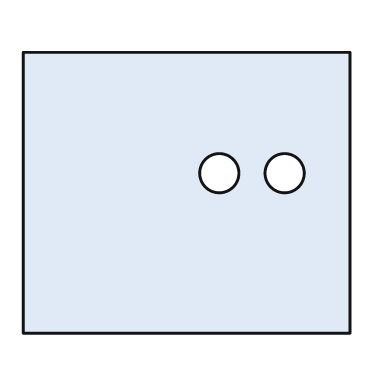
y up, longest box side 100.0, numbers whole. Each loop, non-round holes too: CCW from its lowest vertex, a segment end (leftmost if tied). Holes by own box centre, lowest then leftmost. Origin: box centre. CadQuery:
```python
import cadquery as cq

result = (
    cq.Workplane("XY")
    .moveTo(-50.0, -43.0)
    .lineTo(50.0, -43.0)
    .lineTo(50.0, 43.0)
    .lineTo(-50.0, 43.0)
    .close()
    .moveTo(10.0, 6.0)
    .circle(6.0)
    .moveTo(30.0, 6.0)
    .circle(6.0)
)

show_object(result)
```